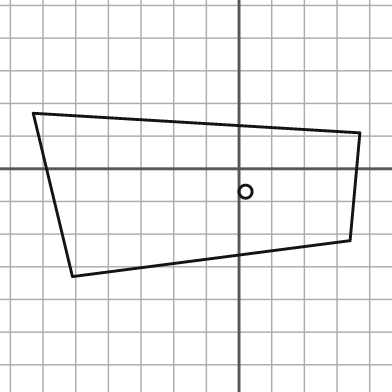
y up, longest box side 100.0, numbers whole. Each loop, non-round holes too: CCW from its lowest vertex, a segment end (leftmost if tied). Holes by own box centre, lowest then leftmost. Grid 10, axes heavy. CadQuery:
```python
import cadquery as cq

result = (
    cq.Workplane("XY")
    .moveTo(-51.0, -33.0)
    .lineTo(34.0, -22.0)
    .lineTo(37.0, 11.0)
    .lineTo(-63.0, 17.0)
    .close()
    .moveTo(2.0, -7.0)
    .circle(2.0)
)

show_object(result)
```